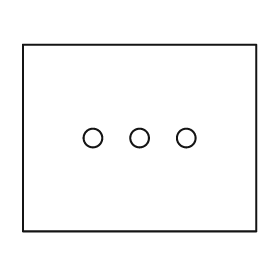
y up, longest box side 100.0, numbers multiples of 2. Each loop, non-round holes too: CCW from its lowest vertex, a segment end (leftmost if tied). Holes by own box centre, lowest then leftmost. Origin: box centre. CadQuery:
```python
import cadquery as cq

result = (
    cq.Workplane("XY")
    .moveTo(-50.0, -40.0)
    .lineTo(50.0, -40.0)
    .lineTo(50.0, 40.0)
    .lineTo(-50.0, 40.0)
    .close()
    .moveTo(-20.0, 0.0)
    .circle(4.0)
    .moveTo(0.0, 0.0)
    .circle(4.0)
    .moveTo(20.0, 0.0)
    .circle(4.0)
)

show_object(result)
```